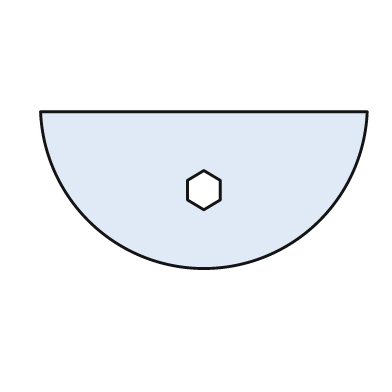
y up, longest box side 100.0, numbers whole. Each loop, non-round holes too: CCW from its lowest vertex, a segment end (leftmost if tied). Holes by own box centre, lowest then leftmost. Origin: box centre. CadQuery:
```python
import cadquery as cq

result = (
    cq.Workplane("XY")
    .moveTo(-50.0, 24.0)
    .threePointArc((0.0, -24.0), (50.0, 24.0))
    .close()
    .moveTo(0.0, -6.0)
    .lineTo(5.0, -3.0)
    .lineTo(5.0, 3.0)
    .lineTo(0.0, 6.0)
    .lineTo(-5.0, 3.0)
    .lineTo(-5.0, -3.0)
    .close()
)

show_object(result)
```